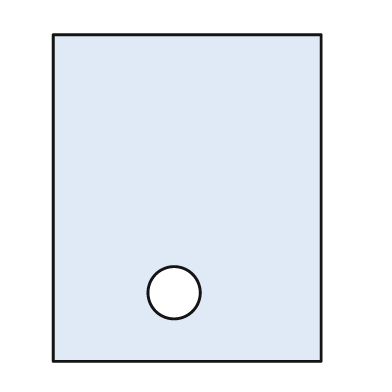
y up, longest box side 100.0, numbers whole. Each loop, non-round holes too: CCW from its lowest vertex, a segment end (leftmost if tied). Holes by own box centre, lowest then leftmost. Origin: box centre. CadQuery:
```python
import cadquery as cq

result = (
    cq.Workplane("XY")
    .moveTo(-41.0, -50.0)
    .lineTo(41.0, -50.0)
    .lineTo(41.0, 50.0)
    .lineTo(-41.0, 50.0)
    .close()
    .moveTo(-4.0, -29.0)
    .circle(8.0)
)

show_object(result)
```